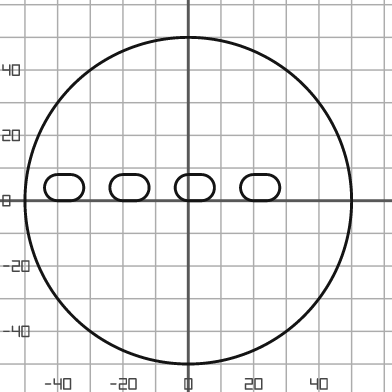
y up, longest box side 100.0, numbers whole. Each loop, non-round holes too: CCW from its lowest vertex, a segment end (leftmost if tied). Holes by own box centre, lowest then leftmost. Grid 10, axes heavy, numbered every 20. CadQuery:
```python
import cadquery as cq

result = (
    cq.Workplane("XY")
    .moveTo(0.0, 0.0)
    .circle(50.0)
    .moveTo(-40.0, 0.0)
    .lineTo(-36.0, 0.0)
    .threePointArc((-32.0, 4.0), (-36.0, 8.0))
    .lineTo(-40.0, 8.0)
    .threePointArc((-44.0, 4.0), (-40.0, 0.0))
    .close()
    .moveTo(-20.0, 0.0)
    .lineTo(-16.0, 0.0)
    .threePointArc((-12.0, 4.0), (-16.0, 8.0))
    .lineTo(-20.0, 8.0)
    .threePointArc((-24.0, 4.0), (-20.0, 0.0))
    .close()
    .moveTo(0.0, 0.0)
    .lineTo(4.0, 0.0)
    .threePointArc((8.0, 4.0), (4.0, 8.0))
    .lineTo(0.0, 8.0)
    .threePointArc((-4.0, 4.0), (0.0, 0.0))
    .close()
    .moveTo(20.0, 0.0)
    .lineTo(24.0, 0.0)
    .threePointArc((28.0, 4.0), (24.0, 8.0))
    .lineTo(20.0, 8.0)
    .threePointArc((16.0, 4.0), (20.0, 0.0))
    .close()
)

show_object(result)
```